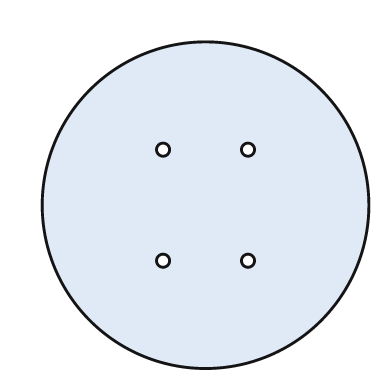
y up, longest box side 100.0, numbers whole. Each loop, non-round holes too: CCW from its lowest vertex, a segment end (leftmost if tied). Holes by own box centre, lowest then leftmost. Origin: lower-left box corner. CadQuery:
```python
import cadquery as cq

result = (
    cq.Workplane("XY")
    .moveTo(50.0, 50.0)
    .circle(50.0)
    .moveTo(37.0, 33.0)
    .circle(2.0)
    .moveTo(63.0, 33.0)
    .circle(2.0)
    .moveTo(37.0, 67.0)
    .circle(2.0)
    .moveTo(63.0, 67.0)
    .circle(2.0)
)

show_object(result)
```